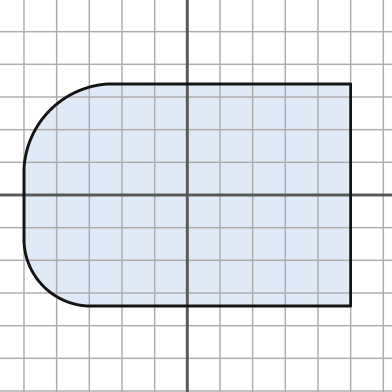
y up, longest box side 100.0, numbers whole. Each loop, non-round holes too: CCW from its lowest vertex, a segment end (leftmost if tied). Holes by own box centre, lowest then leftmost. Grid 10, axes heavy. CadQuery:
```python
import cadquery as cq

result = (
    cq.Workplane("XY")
    .moveTo(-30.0, -34.0)
    .lineTo(50.0, -34.0)
    .lineTo(50.0, 34.0)
    .lineTo(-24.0, 34.0)
    .threePointArc((-42.0, 26.0), (-50.0, 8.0))
    .lineTo(-50.0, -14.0)
    .threePointArc((-44.0, -28.0), (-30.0, -34.0))
    .close()
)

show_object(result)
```